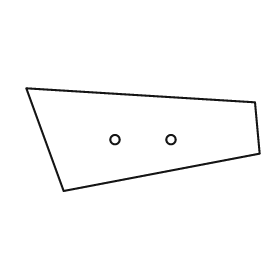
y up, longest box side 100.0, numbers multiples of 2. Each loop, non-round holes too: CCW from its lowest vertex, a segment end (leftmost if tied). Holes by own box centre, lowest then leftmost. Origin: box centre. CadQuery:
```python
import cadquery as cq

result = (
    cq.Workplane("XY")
    .moveTo(-34.0, -22.0)
    .lineTo(50.0, -6.0)
    .lineTo(48.0, 16.0)
    .lineTo(-50.0, 22.0)
    .close()
    .moveTo(-12.0, 0.0)
    .circle(2.0)
    .moveTo(12.0, 0.0)
    .circle(2.0)
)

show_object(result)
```